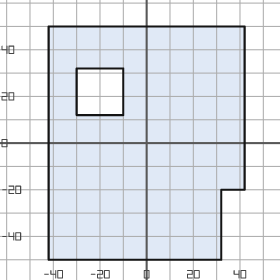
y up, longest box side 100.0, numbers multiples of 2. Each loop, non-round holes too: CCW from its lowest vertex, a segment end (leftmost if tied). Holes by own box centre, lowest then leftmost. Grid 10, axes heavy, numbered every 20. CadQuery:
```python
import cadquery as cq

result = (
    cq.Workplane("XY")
    .moveTo(-42.0, -50.0)
    .lineTo(32.0, -50.0)
    .lineTo(32.0, -20.0)
    .lineTo(42.0, -20.0)
    .lineTo(42.0, 50.0)
    .lineTo(-42.0, 50.0)
    .close()
    .moveTo(-30.0, 12.0)
    .lineTo(-10.0, 12.0)
    .lineTo(-10.0, 32.0)
    .lineTo(-30.0, 32.0)
    .close()
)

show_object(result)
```